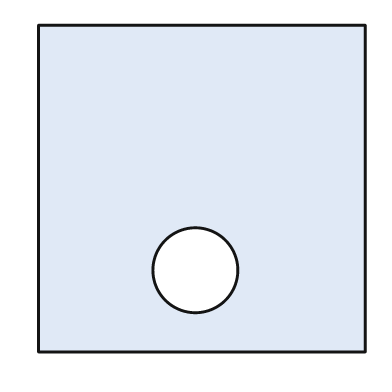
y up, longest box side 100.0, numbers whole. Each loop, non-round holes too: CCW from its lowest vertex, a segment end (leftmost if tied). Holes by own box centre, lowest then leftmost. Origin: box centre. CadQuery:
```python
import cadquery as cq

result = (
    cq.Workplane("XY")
    .moveTo(-50.0, -50.0)
    .lineTo(50.0, -50.0)
    .lineTo(50.0, 50.0)
    .lineTo(-50.0, 50.0)
    .close()
    .moveTo(-2.0, -25.0)
    .circle(13.0)
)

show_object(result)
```